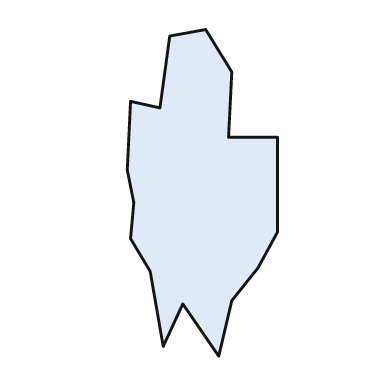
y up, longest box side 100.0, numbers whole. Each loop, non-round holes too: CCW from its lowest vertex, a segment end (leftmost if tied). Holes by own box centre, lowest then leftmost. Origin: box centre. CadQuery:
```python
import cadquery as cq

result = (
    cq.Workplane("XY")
    .moveTo(5.0, -50.0)
    .lineTo(9.0, -33.0)
    .lineTo(17.0, -23.0)
    .lineTo(23.0, -12.0)
    .lineTo(23.0, 17.0)
    .lineTo(8.0, 17.0)
    .lineTo(9.0, 37.0)
    .lineTo(1.0, 50.0)
    .lineTo(-10.0, 48.0)
    .lineTo(-13.0, 26.0)
    .lineTo(-22.0, 28.0)
    .lineTo(-23.0, 7.0)
    .lineTo(-21.0, -3.0)
    .lineTo(-22.0, -14.0)
    .lineTo(-16.0, -24.0)
    .lineTo(-12.0, -47.0)
    .lineTo(-6.0, -34.0)
    .close()
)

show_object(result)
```